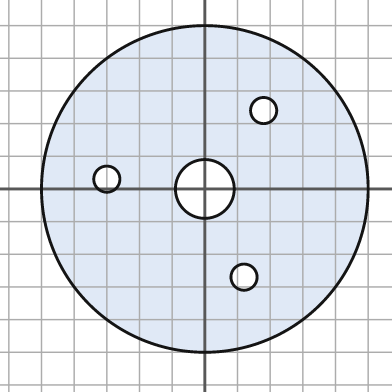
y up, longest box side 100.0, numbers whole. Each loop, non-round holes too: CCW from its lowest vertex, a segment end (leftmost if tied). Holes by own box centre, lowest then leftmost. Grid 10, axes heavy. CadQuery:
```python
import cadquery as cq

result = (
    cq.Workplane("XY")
    .moveTo(0.0, 0.0)
    .circle(50.0)
    .moveTo(12.0, -27.0)
    .circle(4.0)
    .moveTo(0.0, 0.0)
    .circle(9.0)
    .moveTo(-30.0, 3.0)
    .circle(4.0)
    .moveTo(18.0, 24.0)
    .circle(4.0)
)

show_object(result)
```